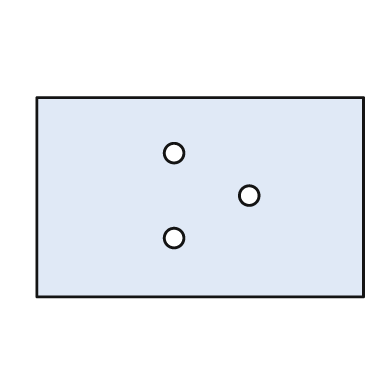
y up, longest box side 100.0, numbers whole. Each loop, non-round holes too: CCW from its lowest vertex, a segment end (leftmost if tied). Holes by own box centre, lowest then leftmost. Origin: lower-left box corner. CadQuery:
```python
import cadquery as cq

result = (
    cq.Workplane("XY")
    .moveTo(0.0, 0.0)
    .lineTo(100.0, 0.0)
    .lineTo(100.0, 61.0)
    .lineTo(0.0, 61.0)
    .close()
    .moveTo(42.0, 18.0)
    .circle(3.0)
    .moveTo(65.0, 31.0)
    .circle(3.0)
    .moveTo(42.0, 44.0)
    .circle(3.0)
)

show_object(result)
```